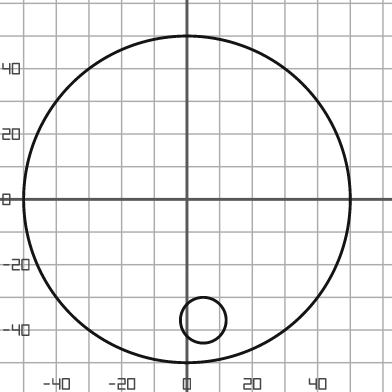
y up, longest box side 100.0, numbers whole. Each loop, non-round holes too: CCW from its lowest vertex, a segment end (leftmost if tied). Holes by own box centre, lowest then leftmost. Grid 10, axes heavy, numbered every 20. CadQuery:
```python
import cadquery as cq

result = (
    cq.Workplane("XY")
    .moveTo(0.0, 0.0)
    .circle(50.0)
    .moveTo(5.0, -37.0)
    .circle(7.0)
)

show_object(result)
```